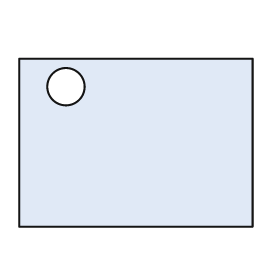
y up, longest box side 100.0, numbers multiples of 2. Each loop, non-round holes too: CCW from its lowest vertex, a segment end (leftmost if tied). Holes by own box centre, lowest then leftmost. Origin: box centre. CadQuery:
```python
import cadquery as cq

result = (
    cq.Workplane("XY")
    .moveTo(-50.0, -36.0)
    .lineTo(50.0, -36.0)
    .lineTo(50.0, 36.0)
    .lineTo(-50.0, 36.0)
    .close()
    .moveTo(-30.0, 24.0)
    .circle(8.0)
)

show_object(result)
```